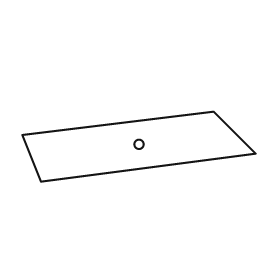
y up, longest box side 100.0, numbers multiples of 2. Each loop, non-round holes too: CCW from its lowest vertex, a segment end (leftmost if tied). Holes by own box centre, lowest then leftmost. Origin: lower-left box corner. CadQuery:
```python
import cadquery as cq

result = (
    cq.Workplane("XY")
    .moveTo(8.0, 0.0)
    .lineTo(100.0, 12.0)
    .lineTo(82.0, 30.0)
    .lineTo(0.0, 20.0)
    .close()
    .moveTo(50.0, 16.0)
    .circle(2.0)
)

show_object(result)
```